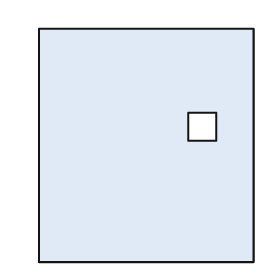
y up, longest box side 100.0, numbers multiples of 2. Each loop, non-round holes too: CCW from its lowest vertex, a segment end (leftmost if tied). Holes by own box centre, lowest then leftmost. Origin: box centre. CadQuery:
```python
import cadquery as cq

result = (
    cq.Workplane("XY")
    .moveTo(-46.0, -50.0)
    .lineTo(46.0, -50.0)
    .lineTo(46.0, 50.0)
    .lineTo(-46.0, 50.0)
    .close()
    .moveTo(18.0, 2.0)
    .lineTo(30.0, 2.0)
    .lineTo(30.0, 14.0)
    .lineTo(18.0, 14.0)
    .close()
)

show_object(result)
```